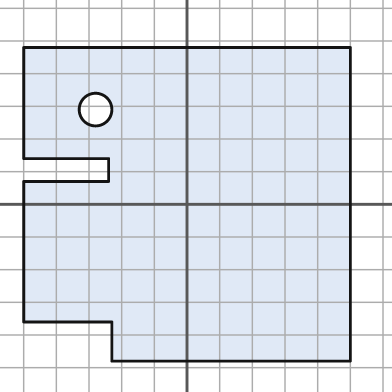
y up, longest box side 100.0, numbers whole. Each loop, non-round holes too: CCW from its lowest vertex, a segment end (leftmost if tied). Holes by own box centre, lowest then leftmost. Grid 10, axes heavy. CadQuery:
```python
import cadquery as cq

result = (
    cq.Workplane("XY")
    .moveTo(-23.0, -48.0)
    .lineTo(50.0, -48.0)
    .lineTo(50.0, 48.0)
    .lineTo(-50.0, 48.0)
    .lineTo(-50.0, 14.0)
    .lineTo(-24.0, 14.0)
    .lineTo(-24.0, 7.0)
    .lineTo(-50.0, 7.0)
    .lineTo(-50.0, -36.0)
    .lineTo(-23.0, -36.0)
    .close()
    .moveTo(-28.0, 29.0)
    .circle(5.0)
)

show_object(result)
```